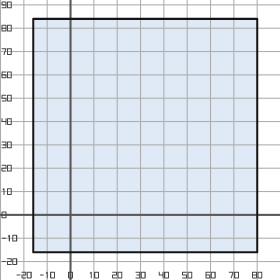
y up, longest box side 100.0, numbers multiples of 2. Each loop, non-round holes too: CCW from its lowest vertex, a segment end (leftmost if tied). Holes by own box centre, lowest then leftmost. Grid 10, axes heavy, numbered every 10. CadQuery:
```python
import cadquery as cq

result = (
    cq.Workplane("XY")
    .moveTo(-16.0, -16.0)
    .lineTo(80.0, -16.0)
    .lineTo(80.0, 84.0)
    .lineTo(-16.0, 84.0)
    .close()
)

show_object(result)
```